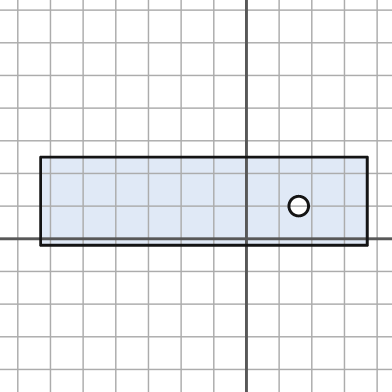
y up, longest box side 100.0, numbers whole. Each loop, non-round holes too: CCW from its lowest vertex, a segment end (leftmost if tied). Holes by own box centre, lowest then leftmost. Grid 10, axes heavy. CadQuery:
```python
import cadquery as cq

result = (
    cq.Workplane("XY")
    .moveTo(-63.0, -2.0)
    .lineTo(37.0, -2.0)
    .lineTo(37.0, 25.0)
    .lineTo(-63.0, 25.0)
    .close()
    .moveTo(16.0, 10.0)
    .circle(3.0)
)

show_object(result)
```